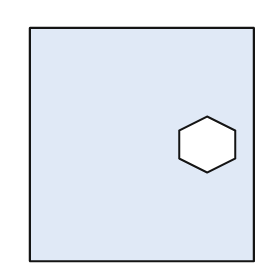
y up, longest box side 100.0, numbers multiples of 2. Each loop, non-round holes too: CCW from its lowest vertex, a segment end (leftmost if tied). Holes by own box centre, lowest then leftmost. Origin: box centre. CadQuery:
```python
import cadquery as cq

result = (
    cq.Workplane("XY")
    .moveTo(-48.0, -50.0)
    .lineTo(48.0, -50.0)
    .lineTo(48.0, 50.0)
    .lineTo(-48.0, 50.0)
    .close()
    .moveTo(28.0, -12.0)
    .lineTo(40.0, -6.0)
    .lineTo(40.0, 6.0)
    .lineTo(28.0, 12.0)
    .lineTo(16.0, 6.0)
    .lineTo(16.0, -6.0)
    .close()
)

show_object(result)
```